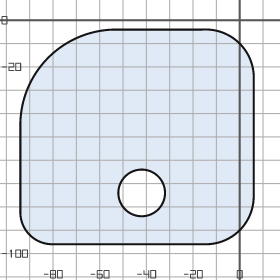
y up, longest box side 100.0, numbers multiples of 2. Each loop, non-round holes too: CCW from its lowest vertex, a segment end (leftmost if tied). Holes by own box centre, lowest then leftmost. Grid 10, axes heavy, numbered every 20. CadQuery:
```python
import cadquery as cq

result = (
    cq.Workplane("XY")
    .moveTo(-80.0, -96.0)
    .lineTo(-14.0, -96.0)
    .threePointArc((0.0, -90.0), (6.0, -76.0))
    .lineTo(6.0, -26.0)
    .threePointArc((0.0, -10.0), (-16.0, -4.0))
    .lineTo(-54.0, -4.0)
    .threePointArc((-82.0, -16.0), (-94.0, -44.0))
    .lineTo(-94.0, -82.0)
    .threePointArc((-90.0, -92.0), (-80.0, -96.0))
    .close()
    .moveTo(-42.0, -74.0)
    .circle(10.0)
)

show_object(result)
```